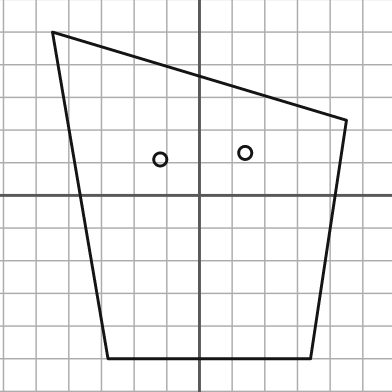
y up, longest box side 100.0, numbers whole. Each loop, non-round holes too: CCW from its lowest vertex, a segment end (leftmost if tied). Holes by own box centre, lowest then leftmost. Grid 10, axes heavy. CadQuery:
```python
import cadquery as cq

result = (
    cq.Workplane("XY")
    .moveTo(-28.0, -50.0)
    .lineTo(34.0, -50.0)
    .lineTo(45.0, 23.0)
    .lineTo(-45.0, 50.0)
    .close()
    .moveTo(-12.0, 11.0)
    .circle(2.0)
    .moveTo(14.0, 13.0)
    .circle(2.0)
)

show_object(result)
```